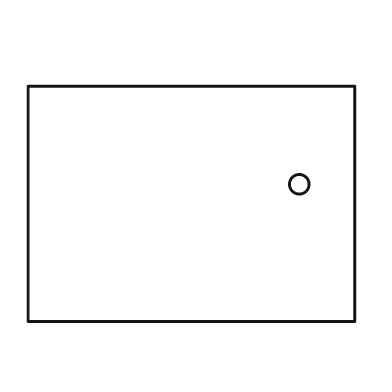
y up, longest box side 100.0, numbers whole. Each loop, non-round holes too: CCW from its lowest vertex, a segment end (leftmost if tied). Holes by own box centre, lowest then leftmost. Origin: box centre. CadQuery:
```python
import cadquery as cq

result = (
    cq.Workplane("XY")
    .moveTo(-50.0, -36.0)
    .lineTo(50.0, -36.0)
    .lineTo(50.0, 36.0)
    .lineTo(-50.0, 36.0)
    .close()
    .moveTo(33.0, 6.0)
    .circle(3.0)
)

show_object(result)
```